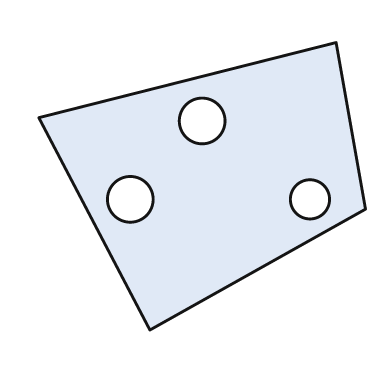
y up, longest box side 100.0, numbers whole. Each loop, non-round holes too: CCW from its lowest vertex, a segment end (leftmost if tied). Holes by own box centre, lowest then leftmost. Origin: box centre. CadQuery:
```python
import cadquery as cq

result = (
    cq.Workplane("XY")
    .moveTo(-16.0, -44.0)
    .lineTo(50.0, -7.0)
    .lineTo(41.0, 44.0)
    .lineTo(-50.0, 21.0)
    .close()
    .moveTo(-22.0, -4.0)
    .circle(7.0)
    .moveTo(33.0, -4.0)
    .circle(6.0)
    .moveTo(0.0, 20.0)
    .circle(7.0)
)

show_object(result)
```